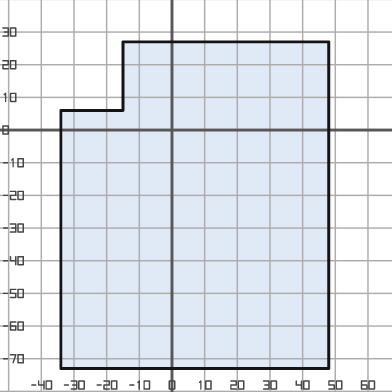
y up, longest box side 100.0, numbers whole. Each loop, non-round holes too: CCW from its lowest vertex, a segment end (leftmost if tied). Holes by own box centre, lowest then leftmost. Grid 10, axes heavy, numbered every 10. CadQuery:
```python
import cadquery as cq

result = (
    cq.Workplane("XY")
    .moveTo(-34.0, -73.0)
    .lineTo(48.0, -73.0)
    .lineTo(48.0, 27.0)
    .lineTo(-15.0, 27.0)
    .lineTo(-15.0, 6.0)
    .lineTo(-34.0, 6.0)
    .close()
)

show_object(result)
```